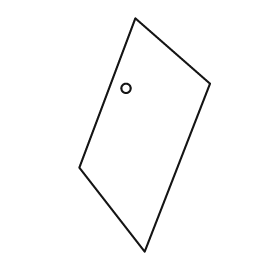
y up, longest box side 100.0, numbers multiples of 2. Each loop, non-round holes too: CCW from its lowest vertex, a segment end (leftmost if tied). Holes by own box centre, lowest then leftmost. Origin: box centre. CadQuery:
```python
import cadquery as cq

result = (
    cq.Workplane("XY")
    .moveTo(0.0, -50.0)
    .lineTo(28.0, 22.0)
    .lineTo(-4.0, 50.0)
    .lineTo(-28.0, -14.0)
    .close()
    .moveTo(-8.0, 20.0)
    .circle(2.0)
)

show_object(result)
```